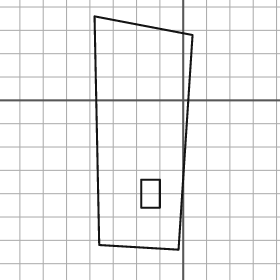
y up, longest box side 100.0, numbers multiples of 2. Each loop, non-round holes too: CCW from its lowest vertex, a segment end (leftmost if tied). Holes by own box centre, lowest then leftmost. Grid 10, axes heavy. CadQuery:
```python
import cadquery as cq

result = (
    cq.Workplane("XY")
    .moveTo(-2.0, -64.0)
    .lineTo(4.0, 28.0)
    .lineTo(-38.0, 36.0)
    .lineTo(-36.0, -62.0)
    .close()
    .moveTo(-18.0, -46.0)
    .lineTo(-10.0, -46.0)
    .lineTo(-10.0, -34.0)
    .lineTo(-18.0, -34.0)
    .close()
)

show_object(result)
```